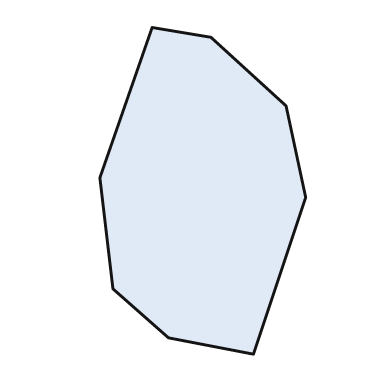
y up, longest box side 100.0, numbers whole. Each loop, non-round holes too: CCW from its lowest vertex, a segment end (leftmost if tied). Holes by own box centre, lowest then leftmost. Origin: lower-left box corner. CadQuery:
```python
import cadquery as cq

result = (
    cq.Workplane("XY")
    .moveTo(47.0, 0.0)
    .lineTo(63.0, 48.0)
    .lineTo(57.0, 76.0)
    .lineTo(34.0, 97.0)
    .lineTo(16.0, 100.0)
    .lineTo(0.0, 54.0)
    .lineTo(4.0, 20.0)
    .lineTo(21.0, 5.0)
    .close()
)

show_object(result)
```